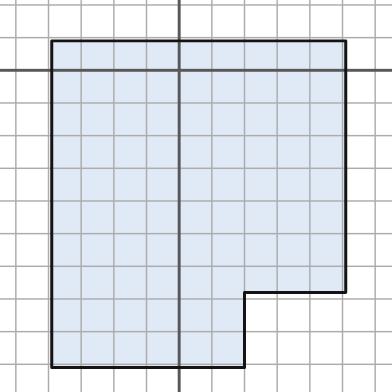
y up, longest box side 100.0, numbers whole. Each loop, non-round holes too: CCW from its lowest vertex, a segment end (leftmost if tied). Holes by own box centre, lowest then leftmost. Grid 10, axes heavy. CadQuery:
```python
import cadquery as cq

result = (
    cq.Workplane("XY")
    .moveTo(-39.0, -91.0)
    .lineTo(20.0, -91.0)
    .lineTo(20.0, -68.0)
    .lineTo(51.0, -68.0)
    .lineTo(51.0, 9.0)
    .lineTo(-39.0, 9.0)
    .close()
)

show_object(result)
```